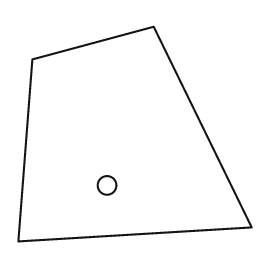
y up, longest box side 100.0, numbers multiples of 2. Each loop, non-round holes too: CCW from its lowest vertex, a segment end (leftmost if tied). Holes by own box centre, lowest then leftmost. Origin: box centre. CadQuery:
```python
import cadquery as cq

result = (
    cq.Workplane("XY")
    .moveTo(-50.0, -46.0)
    .lineTo(50.0, -40.0)
    .lineTo(8.0, 46.0)
    .lineTo(-44.0, 32.0)
    .close()
    .moveTo(-12.0, -22.0)
    .circle(4.0)
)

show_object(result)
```